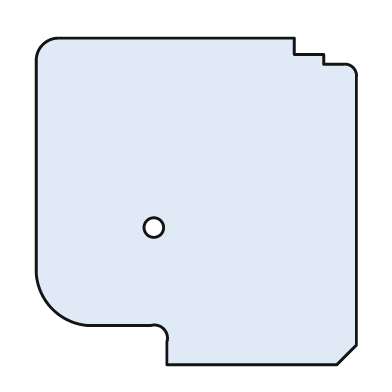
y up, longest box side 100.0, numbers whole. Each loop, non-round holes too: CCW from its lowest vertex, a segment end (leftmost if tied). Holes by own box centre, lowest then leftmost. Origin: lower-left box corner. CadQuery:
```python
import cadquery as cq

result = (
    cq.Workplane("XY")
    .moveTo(40.0, 0.0)
    .lineTo(92.0, 0.0)
    .lineTo(98.0, 6.0)
    .lineTo(98.0, 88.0)
    .threePointArc((97.0, 91.0), (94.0, 92.0))
    .lineTo(88.0, 92.0)
    .lineTo(88.0, 95.0)
    .lineTo(79.0, 95.0)
    .lineTo(79.0, 100.0)
    .lineTo(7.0, 100.0)
    .threePointArc((2.0, 98.0), (0.0, 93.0))
    .lineTo(0.0, 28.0)
    .threePointArc((5.0, 17.0), (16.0, 12.0))
    .lineTo(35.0, 12.0)
    .threePointArc((39.0, 11.0), (40.0, 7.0))
    .close()
    .moveTo(36.0, 42.0)
    .circle(3.0)
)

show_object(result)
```